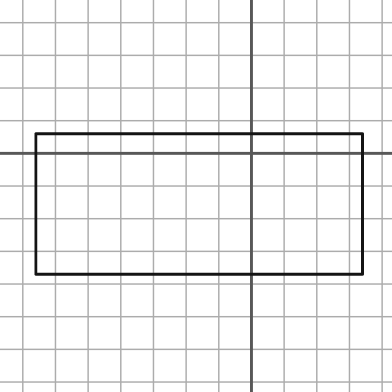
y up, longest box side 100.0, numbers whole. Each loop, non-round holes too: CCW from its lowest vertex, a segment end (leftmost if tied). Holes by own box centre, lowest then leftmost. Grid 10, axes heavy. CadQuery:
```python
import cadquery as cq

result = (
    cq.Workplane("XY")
    .moveTo(-66.0, -37.0)
    .lineTo(34.0, -37.0)
    .lineTo(34.0, 6.0)
    .lineTo(-66.0, 6.0)
    .close()
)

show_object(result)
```